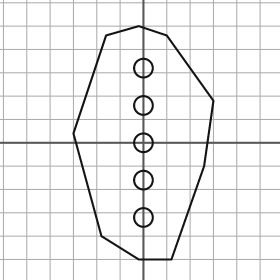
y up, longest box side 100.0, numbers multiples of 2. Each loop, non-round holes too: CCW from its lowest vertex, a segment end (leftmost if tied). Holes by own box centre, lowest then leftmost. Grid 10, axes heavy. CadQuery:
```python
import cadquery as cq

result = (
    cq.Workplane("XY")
    .moveTo(-2.0, -50.0)
    .lineTo(12.0, -50.0)
    .lineTo(26.0, -10.0)
    .lineTo(30.0, 18.0)
    .lineTo(10.0, 46.0)
    .lineTo(-2.0, 50.0)
    .lineTo(-16.0, 46.0)
    .lineTo(-30.0, 4.0)
    .lineTo(-18.0, -40.0)
    .close()
    .moveTo(0.0, -32.0)
    .circle(4.0)
    .moveTo(0.0, -16.0)
    .circle(4.0)
    .moveTo(0.0, 0.0)
    .circle(4.0)
    .moveTo(0.0, 16.0)
    .circle(4.0)
    .moveTo(0.0, 32.0)
    .circle(4.0)
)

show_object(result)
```